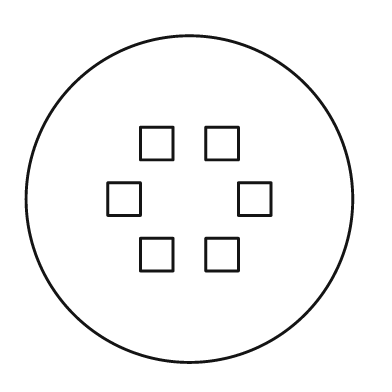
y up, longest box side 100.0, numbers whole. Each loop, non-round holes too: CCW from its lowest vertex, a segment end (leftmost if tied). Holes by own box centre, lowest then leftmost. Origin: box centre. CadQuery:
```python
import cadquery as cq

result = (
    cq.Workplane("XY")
    .moveTo(0.0, 0.0)
    .circle(50.0)
    .moveTo(-15.0, -22.0)
    .lineTo(-5.0, -22.0)
    .lineTo(-5.0, -12.0)
    .lineTo(-15.0, -12.0)
    .close()
    .moveTo(5.0, -22.0)
    .lineTo(15.0, -22.0)
    .lineTo(15.0, -12.0)
    .lineTo(5.0, -12.0)
    .close()
    .moveTo(-25.0, -5.0)
    .lineTo(-15.0, -5.0)
    .lineTo(-15.0, 5.0)
    .lineTo(-25.0, 5.0)
    .close()
    .moveTo(15.0, -5.0)
    .lineTo(25.0, -5.0)
    .lineTo(25.0, 5.0)
    .lineTo(15.0, 5.0)
    .close()
    .moveTo(-15.0, 12.0)
    .lineTo(-5.0, 12.0)
    .lineTo(-5.0, 22.0)
    .lineTo(-15.0, 22.0)
    .close()
    .moveTo(5.0, 12.0)
    .lineTo(15.0, 12.0)
    .lineTo(15.0, 22.0)
    .lineTo(5.0, 22.0)
    .close()
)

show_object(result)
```